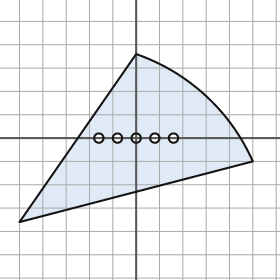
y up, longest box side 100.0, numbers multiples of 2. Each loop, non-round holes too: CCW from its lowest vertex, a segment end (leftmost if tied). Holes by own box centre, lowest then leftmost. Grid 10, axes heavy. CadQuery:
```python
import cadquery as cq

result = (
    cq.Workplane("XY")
    .moveTo(-50.0, -36.0)
    .lineTo(50.0, -10.0)
    .threePointArc((30.0, 18.0), (0.0, 36.0))
    .close()
    .moveTo(-16.0, 0.0)
    .circle(2.0)
    .moveTo(-8.0, 0.0)
    .circle(2.0)
    .moveTo(0.0, 0.0)
    .circle(2.0)
    .moveTo(8.0, 0.0)
    .circle(2.0)
    .moveTo(16.0, 0.0)
    .circle(2.0)
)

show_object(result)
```